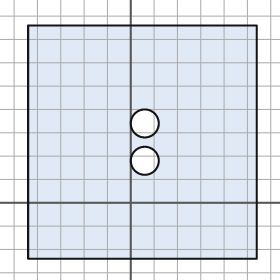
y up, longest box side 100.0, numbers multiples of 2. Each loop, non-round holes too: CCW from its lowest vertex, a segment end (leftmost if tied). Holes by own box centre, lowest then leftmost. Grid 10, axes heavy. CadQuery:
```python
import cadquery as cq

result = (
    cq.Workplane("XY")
    .moveTo(-44.0, -24.0)
    .lineTo(54.0, -24.0)
    .lineTo(54.0, 76.0)
    .lineTo(-44.0, 76.0)
    .close()
    .moveTo(6.0, 18.0)
    .circle(6.0)
    .moveTo(6.0, 34.0)
    .circle(6.0)
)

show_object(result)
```